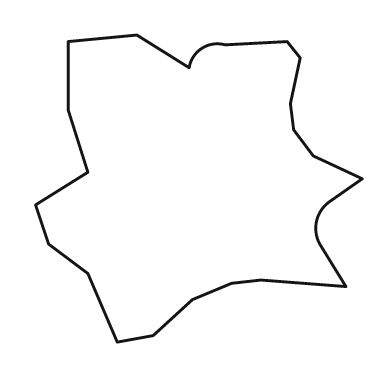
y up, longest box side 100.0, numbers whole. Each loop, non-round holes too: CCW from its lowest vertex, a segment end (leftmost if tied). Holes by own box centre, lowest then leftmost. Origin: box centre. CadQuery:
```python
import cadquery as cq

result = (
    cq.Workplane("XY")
    .moveTo(-25.0, -47.0)
    .lineTo(-14.0, -45.0)
    .lineTo(-2.0, -34.0)
    .lineTo(10.0, -29.0)
    .lineTo(19.0, -28.0)
    .lineTo(45.0, -30.0)
    .lineTo(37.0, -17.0)
    .threePointArc((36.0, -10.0), (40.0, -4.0))
    .lineTo(50.0, 3.0)
    .lineTo(35.0, 10.0)
    .lineTo(29.0, 18.0)
    .lineTo(28.0, 26.0)
    .lineTo(31.0, 40.0)
    .lineTo(27.0, 45.0)
    .lineTo(8.0, 44.0)
    .threePointArc((1.0, 43.0), (-3.0, 37.0))
    .lineTo(-19.0, 47.0)
    .lineTo(-40.0, 45.0)
    .lineTo(-40.0, 24.0)
    .lineTo(-34.0, 5.0)
    .lineTo(-50.0, -5.0)
    .lineTo(-46.0, -17.0)
    .lineTo(-34.0, -26.0)
    .close()
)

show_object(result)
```